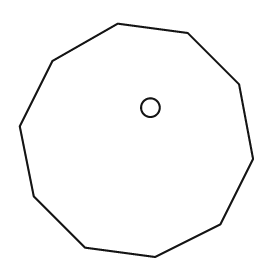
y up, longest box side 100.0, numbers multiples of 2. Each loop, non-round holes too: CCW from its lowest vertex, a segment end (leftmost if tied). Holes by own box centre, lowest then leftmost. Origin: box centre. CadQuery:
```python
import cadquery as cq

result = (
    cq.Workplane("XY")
    .moveTo(8.0, -50.0)
    .lineTo(36.0, -36.0)
    .lineTo(50.0, -8.0)
    .lineTo(44.0, 24.0)
    .lineTo(22.0, 46.0)
    .lineTo(-8.0, 50.0)
    .lineTo(-36.0, 34.0)
    .lineTo(-50.0, 6.0)
    .lineTo(-44.0, -24.0)
    .lineTo(-22.0, -46.0)
    .close()
    .moveTo(6.0, 14.0)
    .circle(4.0)
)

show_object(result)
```